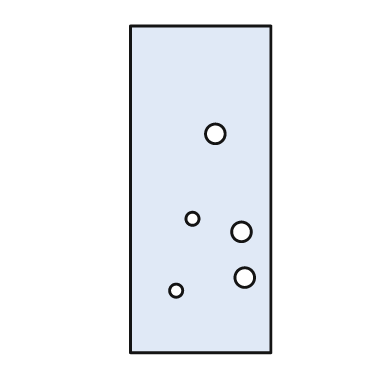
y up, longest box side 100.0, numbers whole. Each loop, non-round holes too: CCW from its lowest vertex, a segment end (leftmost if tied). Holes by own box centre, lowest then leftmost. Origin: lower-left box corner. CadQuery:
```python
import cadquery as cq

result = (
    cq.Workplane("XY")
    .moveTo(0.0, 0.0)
    .lineTo(43.0, 0.0)
    .lineTo(43.0, 100.0)
    .lineTo(0.0, 100.0)
    .close()
    .moveTo(14.0, 19.0)
    .circle(2.0)
    .moveTo(35.0, 23.0)
    .circle(3.0)
    .moveTo(34.0, 37.0)
    .circle(3.0)
    .moveTo(19.0, 41.0)
    .circle(2.0)
    .moveTo(26.0, 67.0)
    .circle(3.0)
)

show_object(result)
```